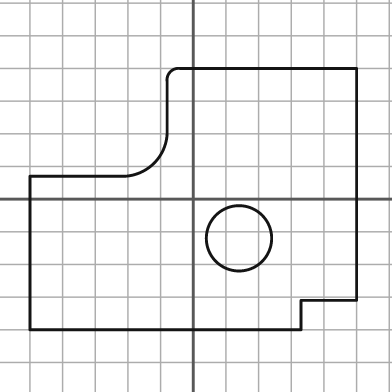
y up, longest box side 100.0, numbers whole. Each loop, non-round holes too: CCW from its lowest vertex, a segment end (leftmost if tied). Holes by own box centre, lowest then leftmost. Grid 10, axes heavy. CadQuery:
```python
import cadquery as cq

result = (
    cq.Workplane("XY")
    .moveTo(-50.0, -40.0)
    .lineTo(33.0, -40.0)
    .lineTo(33.0, -31.0)
    .lineTo(50.0, -31.0)
    .lineTo(50.0, 40.0)
    .lineTo(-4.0, 40.0)
    .threePointArc((-7.0, 39.0), (-8.0, 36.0))
    .lineTo(-8.0, 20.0)
    .threePointArc((-12.0, 11.0), (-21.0, 7.0))
    .lineTo(-50.0, 7.0)
    .close()
    .moveTo(14.0, -12.0)
    .circle(10.0)
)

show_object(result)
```